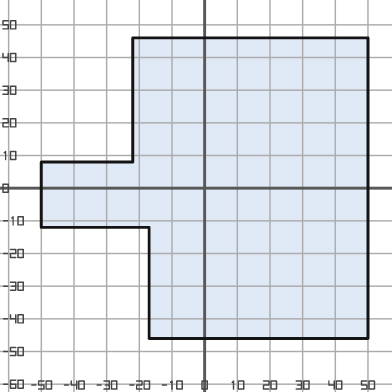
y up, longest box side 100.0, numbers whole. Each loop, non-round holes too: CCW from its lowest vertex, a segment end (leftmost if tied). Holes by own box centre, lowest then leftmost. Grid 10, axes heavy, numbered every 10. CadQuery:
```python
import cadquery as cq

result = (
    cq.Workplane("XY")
    .moveTo(-17.0, -46.0)
    .lineTo(50.0, -46.0)
    .lineTo(50.0, 46.0)
    .lineTo(-22.0, 46.0)
    .lineTo(-22.0, 8.0)
    .lineTo(-50.0, 8.0)
    .lineTo(-50.0, -12.0)
    .lineTo(-17.0, -12.0)
    .close()
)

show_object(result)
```